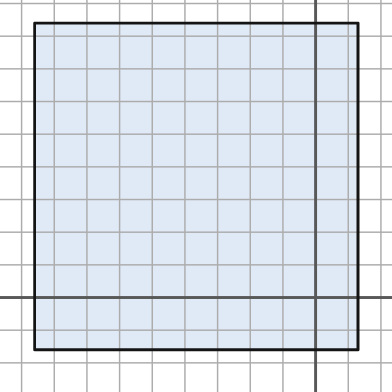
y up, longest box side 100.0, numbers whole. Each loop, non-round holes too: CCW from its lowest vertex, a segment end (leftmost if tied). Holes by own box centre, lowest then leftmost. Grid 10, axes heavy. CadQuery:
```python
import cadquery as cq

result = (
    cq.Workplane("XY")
    .moveTo(-86.0, -16.0)
    .lineTo(13.0, -16.0)
    .lineTo(13.0, 84.0)
    .lineTo(-86.0, 84.0)
    .close()
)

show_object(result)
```